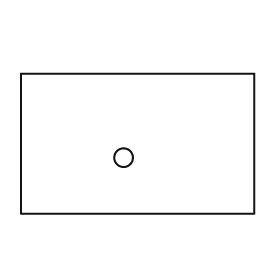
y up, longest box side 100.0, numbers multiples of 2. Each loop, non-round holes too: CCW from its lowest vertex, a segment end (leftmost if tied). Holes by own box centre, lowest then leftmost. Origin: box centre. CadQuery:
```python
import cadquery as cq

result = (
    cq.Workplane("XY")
    .moveTo(-50.0, -30.0)
    .lineTo(50.0, -30.0)
    .lineTo(50.0, 30.0)
    .lineTo(-50.0, 30.0)
    .close()
    .moveTo(-6.0, -6.0)
    .circle(4.0)
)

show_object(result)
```